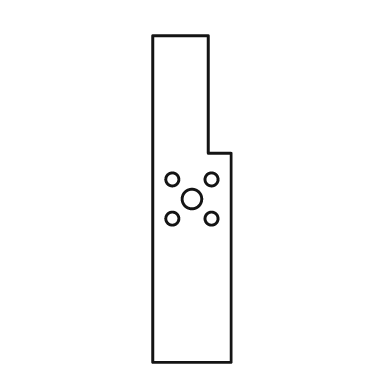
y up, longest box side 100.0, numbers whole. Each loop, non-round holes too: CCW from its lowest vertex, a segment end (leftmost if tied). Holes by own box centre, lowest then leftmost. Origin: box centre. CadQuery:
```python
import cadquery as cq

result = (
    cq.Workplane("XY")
    .moveTo(-12.0, -50.0)
    .lineTo(12.0, -50.0)
    .lineTo(12.0, 14.0)
    .lineTo(5.0, 14.0)
    .lineTo(5.0, 50.0)
    .lineTo(-12.0, 50.0)
    .close()
    .moveTo(-6.0, -6.0)
    .circle(2.0)
    .moveTo(6.0, -6.0)
    .circle(2.0)
    .moveTo(0.0, 0.0)
    .circle(3.0)
    .moveTo(-6.0, 6.0)
    .circle(2.0)
    .moveTo(6.0, 6.0)
    .circle(2.0)
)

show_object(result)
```